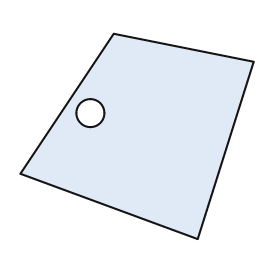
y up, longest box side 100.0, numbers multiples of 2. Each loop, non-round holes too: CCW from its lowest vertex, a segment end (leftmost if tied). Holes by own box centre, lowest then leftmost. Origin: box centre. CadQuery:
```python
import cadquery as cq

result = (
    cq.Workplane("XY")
    .moveTo(26.0, -44.0)
    .lineTo(50.0, 32.0)
    .lineTo(-10.0, 44.0)
    .lineTo(-50.0, -16.0)
    .close()
    .moveTo(-20.0, 10.0)
    .circle(6.0)
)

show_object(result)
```